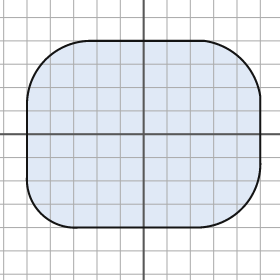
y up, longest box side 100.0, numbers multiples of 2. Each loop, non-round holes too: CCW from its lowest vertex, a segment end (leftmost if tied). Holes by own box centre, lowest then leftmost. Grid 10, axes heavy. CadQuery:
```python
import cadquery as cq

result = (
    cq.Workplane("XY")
    .moveTo(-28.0, -40.0)
    .lineTo(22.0, -40.0)
    .threePointArc((42.0, -32.0), (50.0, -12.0))
    .lineTo(50.0, 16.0)
    .threePointArc((42.0, 32.0), (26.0, 40.0))
    .lineTo(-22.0, 40.0)
    .threePointArc((-42.0, 32.0), (-50.0, 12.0))
    .lineTo(-50.0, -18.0)
    .threePointArc((-44.0, -34.0), (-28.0, -40.0))
    .close()
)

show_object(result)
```